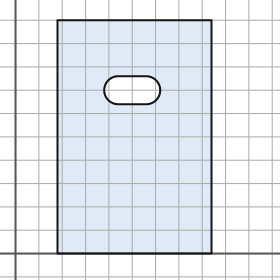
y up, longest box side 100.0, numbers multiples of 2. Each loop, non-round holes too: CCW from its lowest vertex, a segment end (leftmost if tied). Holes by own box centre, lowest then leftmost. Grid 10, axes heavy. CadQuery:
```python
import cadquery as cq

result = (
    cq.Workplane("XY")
    .moveTo(18.0, 0.0)
    .lineTo(84.0, 0.0)
    .lineTo(84.0, 100.0)
    .lineTo(18.0, 100.0)
    .close()
    .moveTo(44.0, 64.0)
    .lineTo(56.0, 64.0)
    .threePointArc((62.0, 70.0), (56.0, 76.0))
    .lineTo(44.0, 76.0)
    .threePointArc((38.0, 70.0), (44.0, 64.0))
    .close()
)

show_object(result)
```